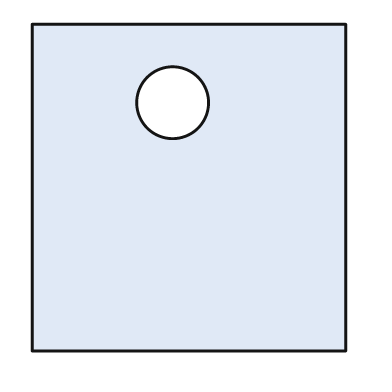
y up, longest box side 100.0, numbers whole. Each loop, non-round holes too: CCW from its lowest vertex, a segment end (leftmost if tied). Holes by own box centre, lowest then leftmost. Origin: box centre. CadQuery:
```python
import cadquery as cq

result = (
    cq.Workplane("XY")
    .moveTo(-48.0, -50.0)
    .lineTo(48.0, -50.0)
    .lineTo(48.0, 50.0)
    .lineTo(-48.0, 50.0)
    .close()
    .moveTo(-5.0, 26.0)
    .circle(11.0)
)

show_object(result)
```